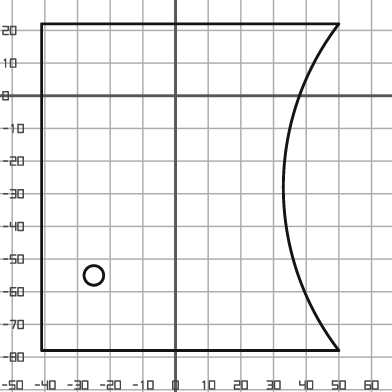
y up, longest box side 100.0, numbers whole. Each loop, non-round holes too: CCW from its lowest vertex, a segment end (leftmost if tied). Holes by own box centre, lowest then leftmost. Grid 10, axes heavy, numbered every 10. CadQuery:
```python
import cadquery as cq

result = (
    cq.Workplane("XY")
    .moveTo(-41.0, -78.0)
    .lineTo(50.0, -78.0)
    .threePointArc((33.0, -28.0), (50.0, 22.0))
    .lineTo(-41.0, 22.0)
    .close()
    .moveTo(-25.0, -55.0)
    .circle(3.0)
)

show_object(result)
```